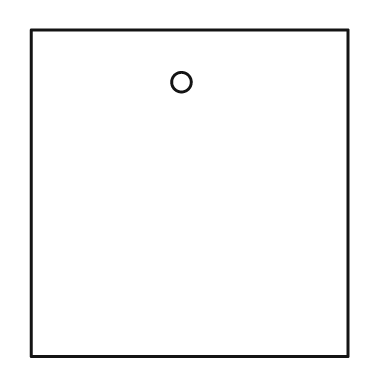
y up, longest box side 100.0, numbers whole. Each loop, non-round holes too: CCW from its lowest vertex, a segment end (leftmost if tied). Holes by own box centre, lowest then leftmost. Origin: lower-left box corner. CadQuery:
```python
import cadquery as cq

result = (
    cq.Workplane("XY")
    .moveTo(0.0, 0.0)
    .lineTo(97.0, 0.0)
    .lineTo(97.0, 100.0)
    .lineTo(0.0, 100.0)
    .close()
    .moveTo(46.0, 84.0)
    .circle(3.0)
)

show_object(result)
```